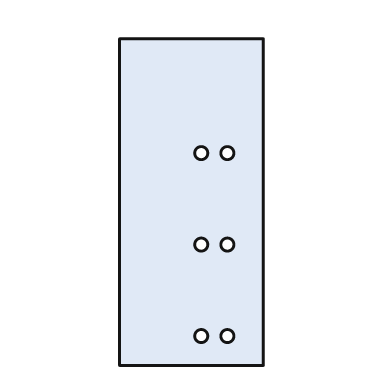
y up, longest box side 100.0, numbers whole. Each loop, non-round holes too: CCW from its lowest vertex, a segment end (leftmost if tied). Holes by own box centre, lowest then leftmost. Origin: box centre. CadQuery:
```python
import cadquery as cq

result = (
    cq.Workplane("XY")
    .moveTo(-22.0, -50.0)
    .lineTo(22.0, -50.0)
    .lineTo(22.0, 50.0)
    .lineTo(-22.0, 50.0)
    .close()
    .moveTo(3.0, -41.0)
    .circle(2.0)
    .moveTo(11.0, -41.0)
    .circle(2.0)
    .moveTo(3.0, -13.0)
    .circle(2.0)
    .moveTo(11.0, -13.0)
    .circle(2.0)
    .moveTo(3.0, 15.0)
    .circle(2.0)
    .moveTo(11.0, 15.0)
    .circle(2.0)
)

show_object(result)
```